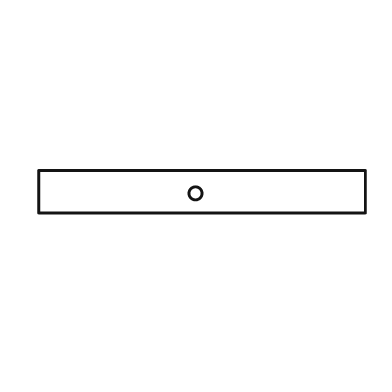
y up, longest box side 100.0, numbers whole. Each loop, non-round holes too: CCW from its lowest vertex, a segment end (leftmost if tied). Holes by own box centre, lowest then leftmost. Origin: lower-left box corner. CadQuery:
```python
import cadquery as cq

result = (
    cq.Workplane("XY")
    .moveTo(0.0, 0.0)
    .lineTo(100.0, 0.0)
    .lineTo(100.0, 13.0)
    .lineTo(0.0, 13.0)
    .close()
    .moveTo(48.0, 6.0)
    .circle(2.0)
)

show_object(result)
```